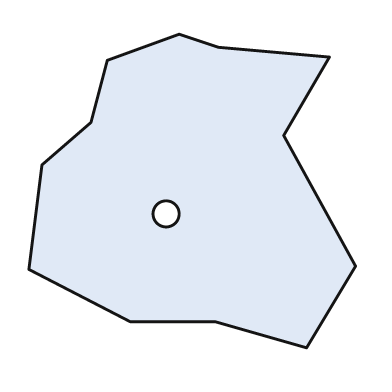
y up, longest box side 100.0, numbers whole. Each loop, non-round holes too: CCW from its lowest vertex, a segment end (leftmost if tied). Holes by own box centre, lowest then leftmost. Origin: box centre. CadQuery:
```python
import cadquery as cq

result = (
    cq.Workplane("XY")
    .moveTo(35.0, -48.0)
    .lineTo(50.0, -23.0)
    .lineTo(28.0, 17.0)
    .lineTo(42.0, 41.0)
    .lineTo(8.0, 44.0)
    .lineTo(-4.0, 48.0)
    .lineTo(-26.0, 40.0)
    .lineTo(-31.0, 21.0)
    .lineTo(-46.0, 8.0)
    .lineTo(-50.0, -24.0)
    .lineTo(-19.0, -40.0)
    .lineTo(7.0, -40.0)
    .close()
    .moveTo(-8.0, -7.0)
    .circle(4.0)
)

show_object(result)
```